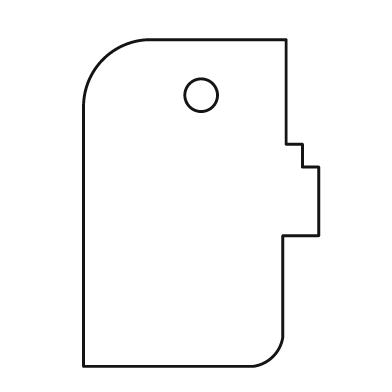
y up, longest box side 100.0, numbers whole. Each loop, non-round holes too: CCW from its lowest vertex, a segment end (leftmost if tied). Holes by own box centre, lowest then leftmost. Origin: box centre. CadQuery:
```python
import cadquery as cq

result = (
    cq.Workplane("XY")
    .moveTo(-36.0, -50.0)
    .lineTo(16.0, -50.0)
    .threePointArc((22.0, -47.0), (25.0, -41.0))
    .lineTo(25.0, -10.0)
    .lineTo(36.0, -10.0)
    .lineTo(36.0, 11.0)
    .lineTo(31.0, 11.0)
    .lineTo(31.0, 18.0)
    .lineTo(26.0, 18.0)
    .lineTo(26.0, 50.0)
    .lineTo(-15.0, 50.0)
    .threePointArc((-30.0, 44.0), (-36.0, 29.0))
    .close()
    .moveTo(0.0, 33.0)
    .circle(5.0)
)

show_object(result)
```